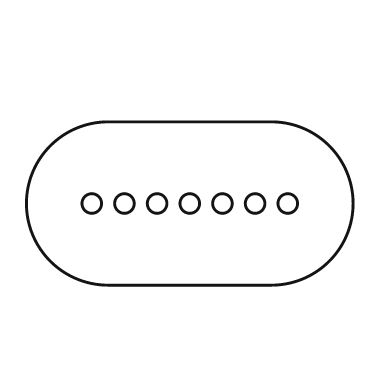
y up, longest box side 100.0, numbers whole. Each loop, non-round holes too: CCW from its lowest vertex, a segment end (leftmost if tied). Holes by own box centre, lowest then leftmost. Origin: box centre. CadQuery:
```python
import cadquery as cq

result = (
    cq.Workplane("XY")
    .moveTo(-25.0, -25.0)
    .lineTo(25.0, -25.0)
    .threePointArc((50.0, 0.0), (25.0, 25.0))
    .lineTo(-25.0, 25.0)
    .threePointArc((-50.0, 0.0), (-25.0, -25.0))
    .close()
    .moveTo(-30.0, 0.0)
    .circle(3.0)
    .moveTo(-20.0, 0.0)
    .circle(3.0)
    .moveTo(-10.0, 0.0)
    .circle(3.0)
    .moveTo(0.0, 0.0)
    .circle(3.0)
    .moveTo(10.0, 0.0)
    .circle(3.0)
    .moveTo(20.0, 0.0)
    .circle(3.0)
    .moveTo(30.0, 0.0)
    .circle(3.0)
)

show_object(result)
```